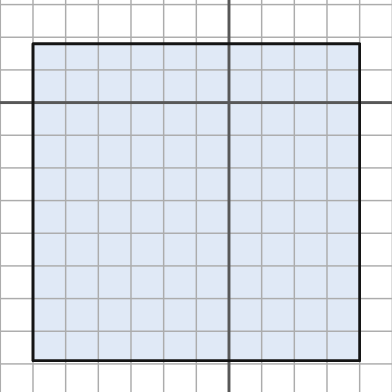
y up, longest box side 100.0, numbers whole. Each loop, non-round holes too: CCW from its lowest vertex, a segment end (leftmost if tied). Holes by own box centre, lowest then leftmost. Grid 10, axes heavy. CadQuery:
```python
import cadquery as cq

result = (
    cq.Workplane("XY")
    .moveTo(-60.0, -79.0)
    .lineTo(40.0, -79.0)
    .lineTo(40.0, 18.0)
    .lineTo(-60.0, 18.0)
    .close()
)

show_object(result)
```